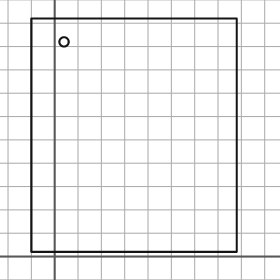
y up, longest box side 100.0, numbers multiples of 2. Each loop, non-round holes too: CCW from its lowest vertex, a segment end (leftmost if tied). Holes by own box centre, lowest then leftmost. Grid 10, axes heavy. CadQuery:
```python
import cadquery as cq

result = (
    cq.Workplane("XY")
    .moveTo(-10.0, 2.0)
    .lineTo(78.0, 2.0)
    .lineTo(78.0, 102.0)
    .lineTo(-10.0, 102.0)
    .close()
    .moveTo(4.0, 92.0)
    .circle(2.0)
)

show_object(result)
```